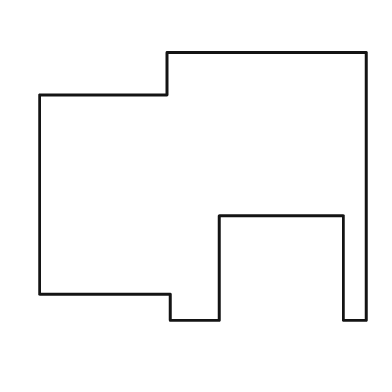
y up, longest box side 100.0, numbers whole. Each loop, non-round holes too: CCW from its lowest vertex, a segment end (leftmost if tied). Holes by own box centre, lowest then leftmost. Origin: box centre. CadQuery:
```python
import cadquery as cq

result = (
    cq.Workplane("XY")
    .moveTo(-10.0, -41.0)
    .lineTo(5.0, -41.0)
    .lineTo(5.0, -9.0)
    .lineTo(43.0, -9.0)
    .lineTo(43.0, -41.0)
    .lineTo(50.0, -41.0)
    .lineTo(50.0, 41.0)
    .lineTo(-11.0, 41.0)
    .lineTo(-11.0, 28.0)
    .lineTo(-50.0, 28.0)
    .lineTo(-50.0, -33.0)
    .lineTo(-10.0, -33.0)
    .close()
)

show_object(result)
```